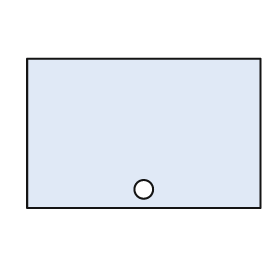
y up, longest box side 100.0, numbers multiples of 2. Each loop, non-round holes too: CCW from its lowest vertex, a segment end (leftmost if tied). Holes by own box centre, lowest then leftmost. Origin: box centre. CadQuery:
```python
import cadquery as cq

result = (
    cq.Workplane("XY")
    .moveTo(-50.0, -32.0)
    .lineTo(50.0, -32.0)
    .lineTo(50.0, 32.0)
    .lineTo(-50.0, 32.0)
    .close()
    .moveTo(0.0, -24.0)
    .circle(4.0)
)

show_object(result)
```